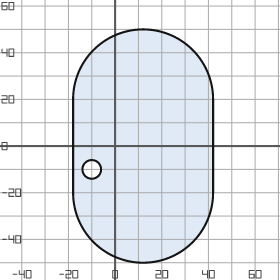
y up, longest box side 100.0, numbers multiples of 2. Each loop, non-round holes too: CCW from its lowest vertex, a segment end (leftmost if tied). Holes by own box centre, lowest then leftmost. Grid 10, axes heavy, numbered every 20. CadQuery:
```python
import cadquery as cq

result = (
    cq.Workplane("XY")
    .moveTo(-18.0, -20.0)
    .threePointArc((12.0, -50.0), (42.0, -20.0))
    .lineTo(42.0, 20.0)
    .threePointArc((12.0, 50.0), (-18.0, 20.0))
    .close()
    .moveTo(-10.0, -10.0)
    .circle(4.0)
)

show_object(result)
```